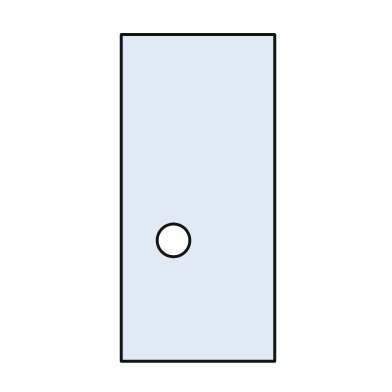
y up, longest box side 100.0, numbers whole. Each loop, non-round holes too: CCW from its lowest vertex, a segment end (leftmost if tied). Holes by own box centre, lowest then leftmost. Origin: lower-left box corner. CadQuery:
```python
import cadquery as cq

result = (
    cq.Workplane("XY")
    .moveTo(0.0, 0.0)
    .lineTo(47.0, 0.0)
    .lineTo(47.0, 100.0)
    .lineTo(0.0, 100.0)
    .close()
    .moveTo(16.0, 37.0)
    .circle(5.0)
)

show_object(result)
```